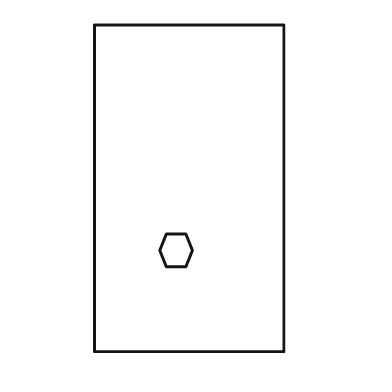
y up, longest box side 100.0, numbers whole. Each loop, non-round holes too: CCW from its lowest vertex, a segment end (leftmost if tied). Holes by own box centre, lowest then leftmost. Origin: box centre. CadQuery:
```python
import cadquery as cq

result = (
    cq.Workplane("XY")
    .moveTo(-29.0, -50.0)
    .lineTo(29.0, -50.0)
    .lineTo(29.0, 50.0)
    .lineTo(-29.0, 50.0)
    .close()
    .moveTo(-7.0, -24.0)
    .lineTo(-1.0, -24.0)
    .lineTo(1.0, -19.0)
    .lineTo(-1.0, -14.0)
    .lineTo(-7.0, -14.0)
    .lineTo(-9.0, -19.0)
    .close()
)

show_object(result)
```